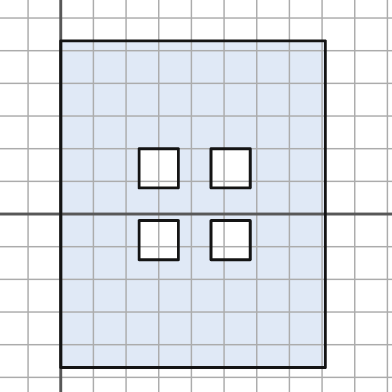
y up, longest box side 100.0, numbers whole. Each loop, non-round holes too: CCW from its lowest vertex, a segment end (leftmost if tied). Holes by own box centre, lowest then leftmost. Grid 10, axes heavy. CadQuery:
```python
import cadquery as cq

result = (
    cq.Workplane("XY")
    .moveTo(0.0, -47.0)
    .lineTo(81.0, -47.0)
    .lineTo(81.0, 53.0)
    .lineTo(0.0, 53.0)
    .close()
    .moveTo(24.0, -14.0)
    .lineTo(36.0, -14.0)
    .lineTo(36.0, -2.0)
    .lineTo(24.0, -2.0)
    .close()
    .moveTo(46.0, -14.0)
    .lineTo(58.0, -14.0)
    .lineTo(58.0, -2.0)
    .lineTo(46.0, -2.0)
    .close()
    .moveTo(24.0, 8.0)
    .lineTo(36.0, 8.0)
    .lineTo(36.0, 20.0)
    .lineTo(24.0, 20.0)
    .close()
    .moveTo(46.0, 8.0)
    .lineTo(58.0, 8.0)
    .lineTo(58.0, 20.0)
    .lineTo(46.0, 20.0)
    .close()
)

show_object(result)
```